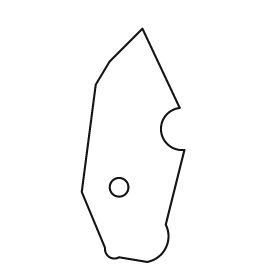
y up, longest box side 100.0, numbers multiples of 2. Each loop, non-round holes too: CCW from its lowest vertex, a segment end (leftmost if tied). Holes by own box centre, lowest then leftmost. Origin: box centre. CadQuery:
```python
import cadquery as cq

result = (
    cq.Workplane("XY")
    .moveTo(6.0, -50.0)
    .threePointArc((14.0, -44.0), (14.0, -34.0))
    .lineTo(22.0, -2.0)
    .threePointArc((12.0, 6.0), (20.0, 16.0))
    .lineTo(4.0, 50.0)
    .lineTo(-10.0, 36.0)
    .lineTo(-16.0, 26.0)
    .lineTo(-22.0, -20.0)
    .lineTo(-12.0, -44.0)
    .threePointArc((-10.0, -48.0), (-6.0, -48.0))
    .close()
    .moveTo(-6.0, -18.0)
    .circle(4.0)
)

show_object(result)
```